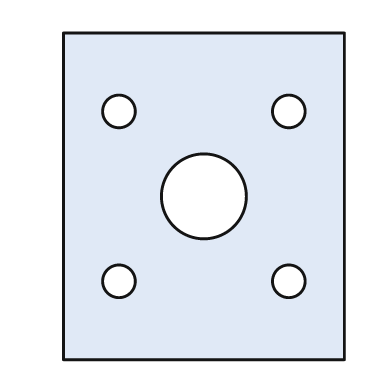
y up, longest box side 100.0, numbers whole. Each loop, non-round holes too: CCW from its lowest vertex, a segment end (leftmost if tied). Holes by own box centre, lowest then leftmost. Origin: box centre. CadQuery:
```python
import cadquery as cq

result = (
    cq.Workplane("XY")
    .moveTo(-43.0, -50.0)
    .lineTo(43.0, -50.0)
    .lineTo(43.0, 50.0)
    .lineTo(-43.0, 50.0)
    .close()
    .moveTo(-26.0, -26.0)
    .circle(5.0)
    .moveTo(26.0, -26.0)
    .circle(5.0)
    .moveTo(0.0, 0.0)
    .circle(13.0)
    .moveTo(-26.0, 26.0)
    .circle(5.0)
    .moveTo(26.0, 26.0)
    .circle(5.0)
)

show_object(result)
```